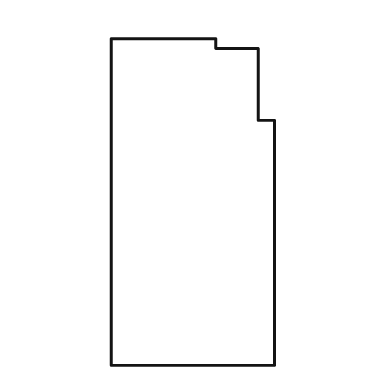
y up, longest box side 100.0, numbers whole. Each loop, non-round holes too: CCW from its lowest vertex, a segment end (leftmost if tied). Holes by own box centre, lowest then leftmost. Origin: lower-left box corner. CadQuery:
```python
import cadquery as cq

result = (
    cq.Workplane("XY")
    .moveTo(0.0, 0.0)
    .lineTo(50.0, 0.0)
    .lineTo(50.0, 75.0)
    .lineTo(45.0, 75.0)
    .lineTo(45.0, 97.0)
    .lineTo(32.0, 97.0)
    .lineTo(32.0, 100.0)
    .lineTo(0.0, 100.0)
    .close()
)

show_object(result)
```